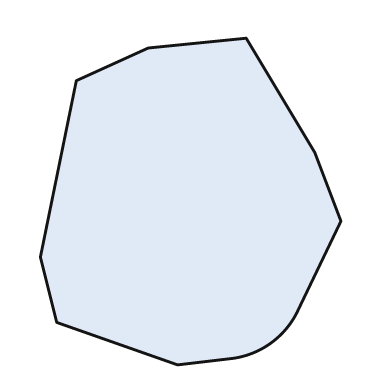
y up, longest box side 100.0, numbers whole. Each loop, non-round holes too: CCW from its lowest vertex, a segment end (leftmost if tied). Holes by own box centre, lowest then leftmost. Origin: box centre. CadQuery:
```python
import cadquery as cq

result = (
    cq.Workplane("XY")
    .moveTo(-4.0, -50.0)
    .lineTo(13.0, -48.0)
    .threePointArc((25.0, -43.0), (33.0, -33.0))
    .lineTo(46.0, -6.0)
    .lineTo(38.0, 15.0)
    .lineTo(17.0, 50.0)
    .lineTo(-13.0, 47.0)
    .lineTo(-35.0, 37.0)
    .lineTo(-46.0, -17.0)
    .lineTo(-41.0, -37.0)
    .close()
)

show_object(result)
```